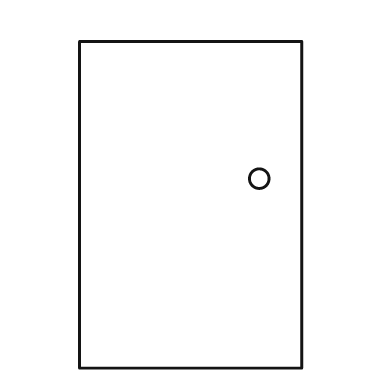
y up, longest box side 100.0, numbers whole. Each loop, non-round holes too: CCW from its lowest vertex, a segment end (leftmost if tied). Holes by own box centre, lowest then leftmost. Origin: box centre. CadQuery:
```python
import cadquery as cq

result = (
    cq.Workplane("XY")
    .moveTo(-34.0, -50.0)
    .lineTo(34.0, -50.0)
    .lineTo(34.0, 50.0)
    .lineTo(-34.0, 50.0)
    .close()
    .moveTo(21.0, 8.0)
    .circle(3.0)
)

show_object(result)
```